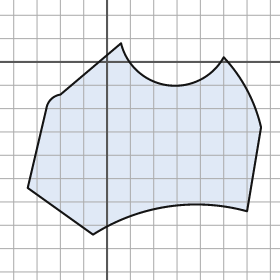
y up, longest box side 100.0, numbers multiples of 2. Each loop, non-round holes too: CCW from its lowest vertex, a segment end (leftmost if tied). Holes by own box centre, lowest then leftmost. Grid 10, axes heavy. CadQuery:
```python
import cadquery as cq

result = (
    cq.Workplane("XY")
    .moveTo(-6.0, -74.0)
    .threePointArc((26.0, -62.0), (60.0, -64.0))
    .lineTo(66.0, -28.0)
    .threePointArc((60.0, -12.0), (50.0, 2.0))
    .threePointArc((26.0, -10.0), (6.0, 8.0))
    .lineTo(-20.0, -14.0)
    .threePointArc((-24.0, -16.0), (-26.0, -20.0))
    .lineTo(-34.0, -54.0)
    .close()
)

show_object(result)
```